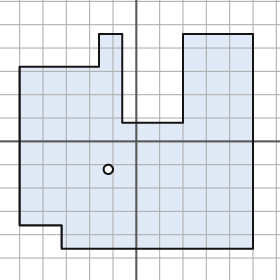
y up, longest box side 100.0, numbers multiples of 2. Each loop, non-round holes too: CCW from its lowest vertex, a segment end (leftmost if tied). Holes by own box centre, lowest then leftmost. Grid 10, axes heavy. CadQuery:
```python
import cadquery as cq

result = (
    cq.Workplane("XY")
    .moveTo(-32.0, -46.0)
    .lineTo(50.0, -46.0)
    .lineTo(50.0, 46.0)
    .lineTo(20.0, 46.0)
    .lineTo(20.0, 8.0)
    .lineTo(-6.0, 8.0)
    .lineTo(-6.0, 46.0)
    .lineTo(-16.0, 46.0)
    .lineTo(-16.0, 32.0)
    .lineTo(-50.0, 32.0)
    .lineTo(-50.0, -36.0)
    .lineTo(-32.0, -36.0)
    .close()
    .moveTo(-12.0, -12.0)
    .circle(2.0)
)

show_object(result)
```